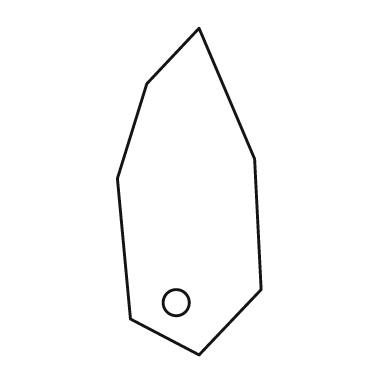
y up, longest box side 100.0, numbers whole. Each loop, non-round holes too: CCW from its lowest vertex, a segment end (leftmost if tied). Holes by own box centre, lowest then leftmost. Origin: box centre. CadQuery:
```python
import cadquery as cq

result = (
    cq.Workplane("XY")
    .moveTo(3.0, -50.0)
    .lineTo(22.0, -30.0)
    .lineTo(20.0, 10.0)
    .lineTo(3.0, 50.0)
    .lineTo(-13.0, 33.0)
    .lineTo(-22.0, 4.0)
    .lineTo(-18.0, -39.0)
    .close()
    .moveTo(-4.0, -34.0)
    .circle(4.0)
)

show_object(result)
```